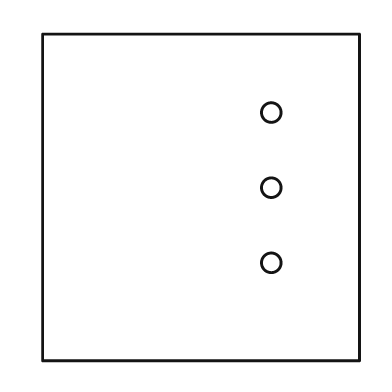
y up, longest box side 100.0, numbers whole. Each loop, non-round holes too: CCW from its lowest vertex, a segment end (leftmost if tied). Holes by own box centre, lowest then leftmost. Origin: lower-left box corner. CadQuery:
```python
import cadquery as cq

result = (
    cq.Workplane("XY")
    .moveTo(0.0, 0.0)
    .lineTo(97.0, 0.0)
    .lineTo(97.0, 100.0)
    .lineTo(0.0, 100.0)
    .close()
    .moveTo(70.0, 30.0)
    .circle(3.0)
    .moveTo(70.0, 53.0)
    .circle(3.0)
    .moveTo(70.0, 76.0)
    .circle(3.0)
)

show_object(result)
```